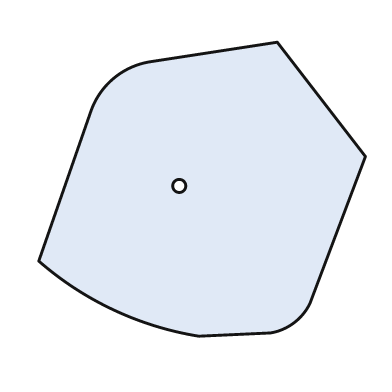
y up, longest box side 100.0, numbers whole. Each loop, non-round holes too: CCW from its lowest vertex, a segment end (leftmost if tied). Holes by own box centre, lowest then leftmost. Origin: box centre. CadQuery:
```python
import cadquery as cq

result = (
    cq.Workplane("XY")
    .moveTo(-1.0, -45.0)
    .lineTo(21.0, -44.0)
    .threePointArc((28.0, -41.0), (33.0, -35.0))
    .lineTo(50.0, 10.0)
    .lineTo(23.0, 45.0)
    .lineTo(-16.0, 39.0)
    .threePointArc((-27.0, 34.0), (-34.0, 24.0))
    .lineTo(-50.0, -22.0)
    .threePointArc((-27.0, -37.0), (-1.0, -45.0))
    .close()
    .moveTo(-7.0, 1.0)
    .circle(2.0)
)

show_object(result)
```